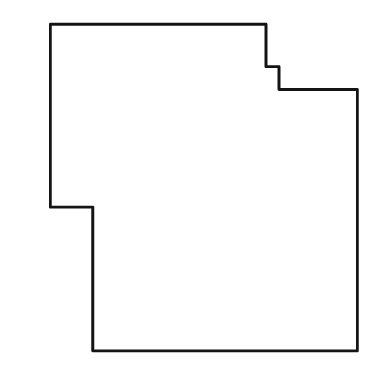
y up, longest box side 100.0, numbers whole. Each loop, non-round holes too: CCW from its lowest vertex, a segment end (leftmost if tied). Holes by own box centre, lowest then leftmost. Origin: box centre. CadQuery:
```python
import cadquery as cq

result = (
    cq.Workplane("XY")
    .moveTo(-34.0, -50.0)
    .lineTo(47.0, -50.0)
    .lineTo(47.0, 30.0)
    .lineTo(23.0, 30.0)
    .lineTo(23.0, 37.0)
    .lineTo(19.0, 37.0)
    .lineTo(19.0, 50.0)
    .lineTo(-47.0, 50.0)
    .lineTo(-47.0, -6.0)
    .lineTo(-34.0, -6.0)
    .close()
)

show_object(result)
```